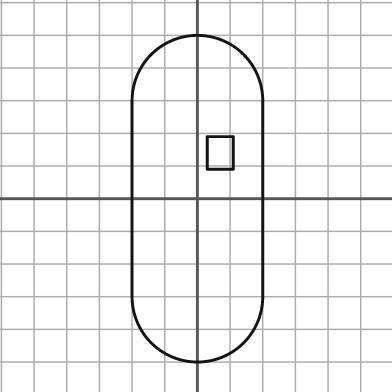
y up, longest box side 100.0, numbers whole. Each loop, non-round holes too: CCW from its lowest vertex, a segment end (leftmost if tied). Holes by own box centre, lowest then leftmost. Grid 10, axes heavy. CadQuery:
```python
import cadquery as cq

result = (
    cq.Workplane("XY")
    .moveTo(-20.0, -30.0)
    .threePointArc((0.0, -50.0), (20.0, -30.0))
    .lineTo(20.0, 30.0)
    .threePointArc((0.0, 50.0), (-20.0, 30.0))
    .close()
    .moveTo(3.0, 9.0)
    .lineTo(11.0, 9.0)
    .lineTo(11.0, 19.0)
    .lineTo(3.0, 19.0)
    .close()
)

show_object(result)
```